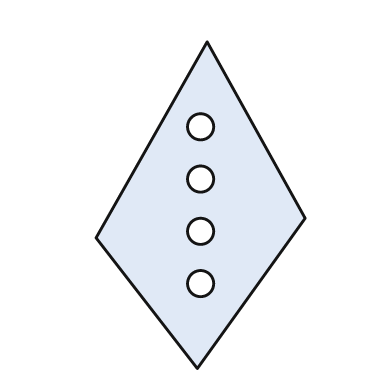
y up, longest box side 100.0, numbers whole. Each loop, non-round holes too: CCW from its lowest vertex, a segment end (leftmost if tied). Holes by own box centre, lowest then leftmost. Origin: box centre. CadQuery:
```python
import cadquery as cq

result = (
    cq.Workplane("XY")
    .moveTo(-1.0, -50.0)
    .lineTo(32.0, -4.0)
    .lineTo(2.0, 50.0)
    .lineTo(-32.0, -10.0)
    .close()
    .moveTo(0.0, -24.0)
    .circle(4.0)
    .moveTo(0.0, -8.0)
    .circle(4.0)
    .moveTo(0.0, 8.0)
    .circle(4.0)
    .moveTo(0.0, 24.0)
    .circle(4.0)
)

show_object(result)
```